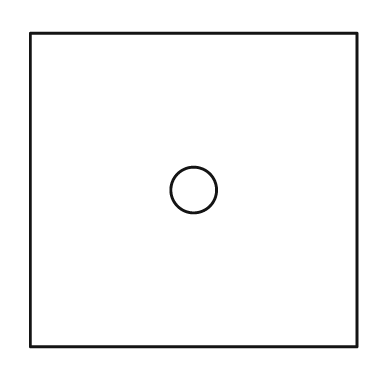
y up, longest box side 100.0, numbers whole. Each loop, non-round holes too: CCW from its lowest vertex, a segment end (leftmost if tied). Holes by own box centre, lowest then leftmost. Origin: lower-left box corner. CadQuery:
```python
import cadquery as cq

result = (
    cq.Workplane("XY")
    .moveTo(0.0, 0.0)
    .lineTo(100.0, 0.0)
    .lineTo(100.0, 96.0)
    .lineTo(0.0, 96.0)
    .close()
    .moveTo(50.0, 48.0)
    .circle(7.0)
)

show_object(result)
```